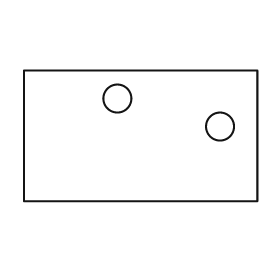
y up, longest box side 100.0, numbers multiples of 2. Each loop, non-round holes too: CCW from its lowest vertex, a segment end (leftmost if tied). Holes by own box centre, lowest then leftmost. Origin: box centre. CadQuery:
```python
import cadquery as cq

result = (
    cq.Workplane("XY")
    .moveTo(-50.0, -28.0)
    .lineTo(50.0, -28.0)
    .lineTo(50.0, 28.0)
    .lineTo(-50.0, 28.0)
    .close()
    .moveTo(34.0, 4.0)
    .circle(6.0)
    .moveTo(-10.0, 16.0)
    .circle(6.0)
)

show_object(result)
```